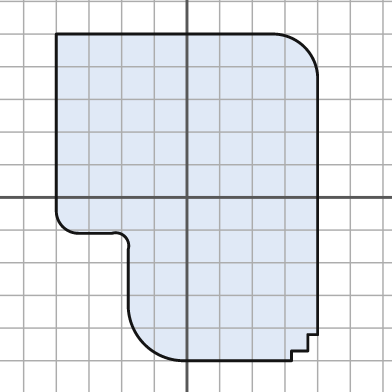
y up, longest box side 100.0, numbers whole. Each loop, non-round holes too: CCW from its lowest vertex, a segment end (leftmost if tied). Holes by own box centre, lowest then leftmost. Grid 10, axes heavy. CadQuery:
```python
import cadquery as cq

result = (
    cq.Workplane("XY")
    .moveTo(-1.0, -50.0)
    .lineTo(32.0, -50.0)
    .lineTo(32.0, -47.0)
    .lineTo(37.0, -47.0)
    .lineTo(37.0, -42.0)
    .lineTo(40.0, -42.0)
    .lineTo(40.0, 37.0)
    .threePointArc((36.0, 46.0), (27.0, 50.0))
    .lineTo(-40.0, 50.0)
    .lineTo(-40.0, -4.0)
    .threePointArc((-38.0, -9.0), (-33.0, -11.0))
    .lineTo(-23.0, -11.0)
    .threePointArc((-19.0, -12.0), (-18.0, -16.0))
    .lineTo(-18.0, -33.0)
    .threePointArc((-13.0, -45.0), (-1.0, -50.0))
    .close()
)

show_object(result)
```